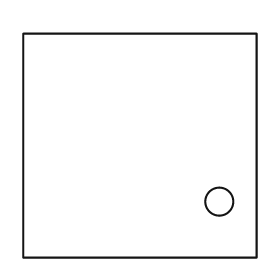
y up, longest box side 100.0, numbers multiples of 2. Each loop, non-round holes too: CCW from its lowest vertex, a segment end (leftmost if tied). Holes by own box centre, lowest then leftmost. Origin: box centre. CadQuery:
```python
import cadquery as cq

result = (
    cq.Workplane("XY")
    .moveTo(-50.0, -48.0)
    .lineTo(50.0, -48.0)
    .lineTo(50.0, 48.0)
    .lineTo(-50.0, 48.0)
    .close()
    .moveTo(34.0, -24.0)
    .circle(6.0)
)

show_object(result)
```